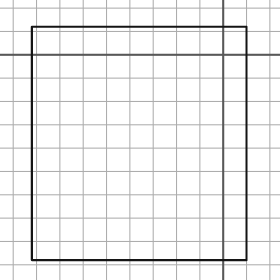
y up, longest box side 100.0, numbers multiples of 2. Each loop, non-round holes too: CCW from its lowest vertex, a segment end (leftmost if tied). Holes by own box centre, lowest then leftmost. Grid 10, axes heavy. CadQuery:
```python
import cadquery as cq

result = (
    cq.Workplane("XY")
    .moveTo(-82.0, -88.0)
    .lineTo(10.0, -88.0)
    .lineTo(10.0, 12.0)
    .lineTo(-82.0, 12.0)
    .close()
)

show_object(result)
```